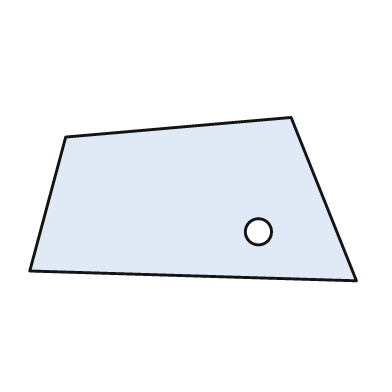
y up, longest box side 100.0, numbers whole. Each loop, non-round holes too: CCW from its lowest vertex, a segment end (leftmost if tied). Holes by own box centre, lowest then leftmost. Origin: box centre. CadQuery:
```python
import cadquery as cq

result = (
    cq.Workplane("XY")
    .moveTo(50.0, -25.0)
    .lineTo(30.0, 25.0)
    .lineTo(-39.0, 19.0)
    .lineTo(-50.0, -22.0)
    .close()
    .moveTo(20.0, -10.0)
    .circle(4.0)
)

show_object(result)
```